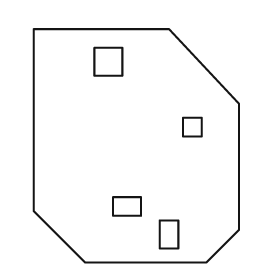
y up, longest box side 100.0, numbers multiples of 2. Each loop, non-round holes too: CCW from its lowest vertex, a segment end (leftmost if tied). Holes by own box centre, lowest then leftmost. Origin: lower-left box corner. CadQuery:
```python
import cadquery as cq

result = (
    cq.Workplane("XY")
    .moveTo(22.0, 0.0)
    .lineTo(74.0, 0.0)
    .lineTo(88.0, 14.0)
    .lineTo(88.0, 68.0)
    .lineTo(58.0, 100.0)
    .lineTo(0.0, 100.0)
    .lineTo(0.0, 22.0)
    .close()
    .moveTo(54.0, 6.0)
    .lineTo(62.0, 6.0)
    .lineTo(62.0, 18.0)
    .lineTo(54.0, 18.0)
    .close()
    .moveTo(34.0, 20.0)
    .lineTo(46.0, 20.0)
    .lineTo(46.0, 28.0)
    .lineTo(34.0, 28.0)
    .close()
    .moveTo(64.0, 54.0)
    .lineTo(72.0, 54.0)
    .lineTo(72.0, 62.0)
    .lineTo(64.0, 62.0)
    .close()
    .moveTo(26.0, 80.0)
    .lineTo(38.0, 80.0)
    .lineTo(38.0, 92.0)
    .lineTo(26.0, 92.0)
    .close()
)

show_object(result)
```